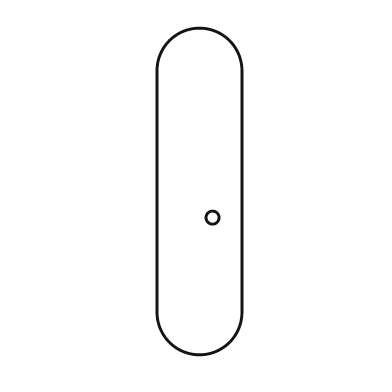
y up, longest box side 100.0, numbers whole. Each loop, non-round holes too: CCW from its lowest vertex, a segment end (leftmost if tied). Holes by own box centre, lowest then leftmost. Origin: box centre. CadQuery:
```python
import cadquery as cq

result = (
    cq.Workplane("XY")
    .moveTo(-13.0, -37.0)
    .threePointArc((0.0, -50.0), (13.0, -37.0))
    .lineTo(13.0, 37.0)
    .threePointArc((0.0, 50.0), (-13.0, 37.0))
    .close()
    .moveTo(4.0, -8.0)
    .circle(2.0)
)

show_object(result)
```